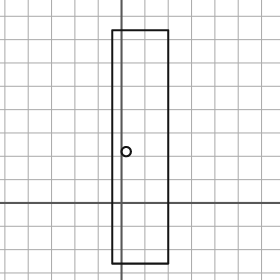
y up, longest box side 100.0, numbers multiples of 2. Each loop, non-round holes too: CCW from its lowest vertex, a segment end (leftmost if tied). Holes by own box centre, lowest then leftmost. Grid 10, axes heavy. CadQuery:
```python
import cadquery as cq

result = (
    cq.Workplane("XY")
    .moveTo(-4.0, -26.0)
    .lineTo(20.0, -26.0)
    .lineTo(20.0, 74.0)
    .lineTo(-4.0, 74.0)
    .close()
    .moveTo(2.0, 22.0)
    .circle(2.0)
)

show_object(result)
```